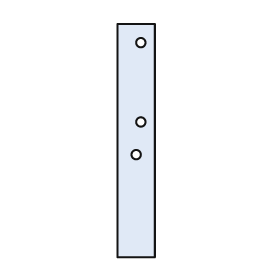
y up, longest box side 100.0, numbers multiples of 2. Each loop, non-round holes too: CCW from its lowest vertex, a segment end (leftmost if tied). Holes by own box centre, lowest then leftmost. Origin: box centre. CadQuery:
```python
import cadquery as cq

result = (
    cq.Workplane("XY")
    .moveTo(-8.0, -50.0)
    .lineTo(8.0, -50.0)
    .lineTo(8.0, 50.0)
    .lineTo(-8.0, 50.0)
    .close()
    .moveTo(0.0, -6.0)
    .circle(2.0)
    .moveTo(2.0, 8.0)
    .circle(2.0)
    .moveTo(2.0, 42.0)
    .circle(2.0)
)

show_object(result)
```